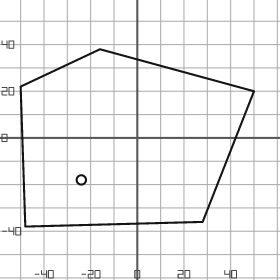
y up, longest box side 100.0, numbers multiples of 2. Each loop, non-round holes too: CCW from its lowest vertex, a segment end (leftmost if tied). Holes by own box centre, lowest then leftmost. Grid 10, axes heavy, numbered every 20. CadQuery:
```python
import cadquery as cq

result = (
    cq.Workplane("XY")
    .moveTo(-48.0, -38.0)
    .lineTo(28.0, -36.0)
    .lineTo(50.0, 20.0)
    .lineTo(-16.0, 38.0)
    .lineTo(-50.0, 22.0)
    .close()
    .moveTo(-24.0, -18.0)
    .circle(2.0)
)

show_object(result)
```